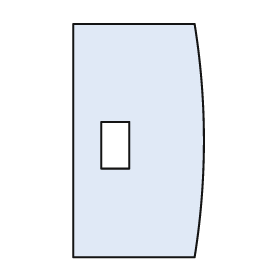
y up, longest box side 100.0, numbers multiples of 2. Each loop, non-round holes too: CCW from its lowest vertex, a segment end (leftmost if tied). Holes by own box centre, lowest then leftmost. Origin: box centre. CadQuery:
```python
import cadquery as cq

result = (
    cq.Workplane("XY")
    .moveTo(-28.0, -50.0)
    .lineTo(24.0, -50.0)
    .threePointArc((28.0, 0.0), (24.0, 50.0))
    .lineTo(-28.0, 50.0)
    .close()
    .moveTo(-16.0, -12.0)
    .lineTo(-4.0, -12.0)
    .lineTo(-4.0, 8.0)
    .lineTo(-16.0, 8.0)
    .close()
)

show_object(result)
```